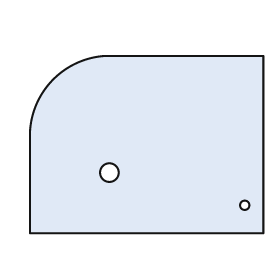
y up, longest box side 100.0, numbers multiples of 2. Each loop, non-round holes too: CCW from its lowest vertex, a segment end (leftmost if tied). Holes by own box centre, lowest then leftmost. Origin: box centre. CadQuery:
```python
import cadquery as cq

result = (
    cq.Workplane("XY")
    .moveTo(-50.0, -38.0)
    .lineTo(50.0, -38.0)
    .lineTo(50.0, 38.0)
    .lineTo(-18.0, 38.0)
    .threePointArc((-40.0, 28.0), (-50.0, 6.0))
    .close()
    .moveTo(42.0, -26.0)
    .circle(2.0)
    .moveTo(-16.0, -12.0)
    .circle(4.0)
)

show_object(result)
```